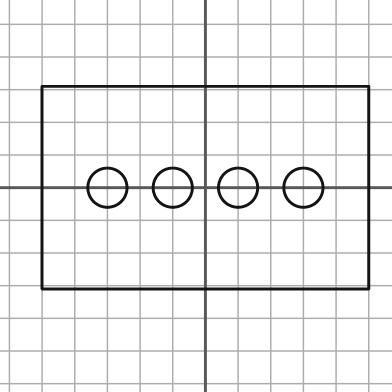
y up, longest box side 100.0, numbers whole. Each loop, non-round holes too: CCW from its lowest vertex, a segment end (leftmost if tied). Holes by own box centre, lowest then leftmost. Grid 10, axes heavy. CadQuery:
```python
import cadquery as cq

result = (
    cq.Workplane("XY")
    .moveTo(-50.0, -31.0)
    .lineTo(50.0, -31.0)
    .lineTo(50.0, 31.0)
    .lineTo(-50.0, 31.0)
    .close()
    .moveTo(-30.0, 0.0)
    .circle(6.0)
    .moveTo(-10.0, 0.0)
    .circle(6.0)
    .moveTo(10.0, 0.0)
    .circle(6.0)
    .moveTo(30.0, 0.0)
    .circle(6.0)
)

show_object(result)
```